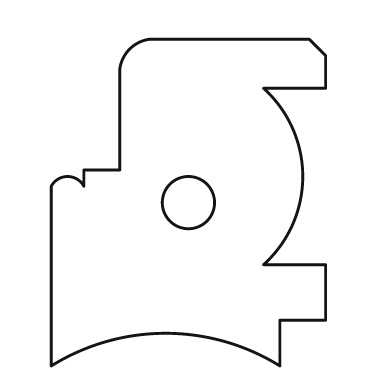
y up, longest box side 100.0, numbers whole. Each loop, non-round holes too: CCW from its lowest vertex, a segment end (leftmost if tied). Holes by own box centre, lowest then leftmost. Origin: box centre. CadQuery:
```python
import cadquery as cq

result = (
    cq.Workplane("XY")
    .moveTo(-42.0, -50.0)
    .threePointArc((-7.0, -40.0), (28.0, -50.0))
    .lineTo(28.0, -36.0)
    .lineTo(42.0, -36.0)
    .lineTo(42.0, -19.0)
    .lineTo(23.0, -19.0)
    .threePointArc((35.0, 8.0), (23.0, 35.0))
    .lineTo(42.0, 35.0)
    .lineTo(42.0, 45.0)
    .lineTo(37.0, 50.0)
    .lineTo(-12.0, 50.0)
    .threePointArc((-18.0, 47.0), (-21.0, 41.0))
    .lineTo(-21.0, 10.0)
    .lineTo(-32.0, 10.0)
    .lineTo(-32.0, 5.0)
    .threePointArc((-37.0, 8.0), (-42.0, 5.0))
    .close()
    .moveTo(0.0, 0.0)
    .circle(8.0)
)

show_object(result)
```